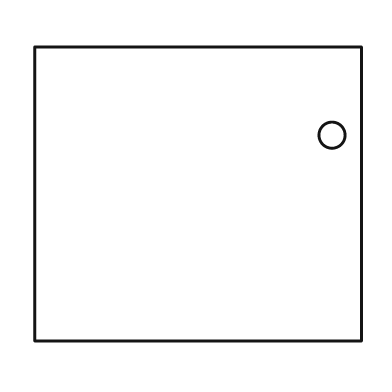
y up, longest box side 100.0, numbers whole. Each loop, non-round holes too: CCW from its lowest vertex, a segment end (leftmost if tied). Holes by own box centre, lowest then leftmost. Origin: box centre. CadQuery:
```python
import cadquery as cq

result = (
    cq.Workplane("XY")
    .moveTo(-50.0, -45.0)
    .lineTo(50.0, -45.0)
    .lineTo(50.0, 45.0)
    .lineTo(-50.0, 45.0)
    .close()
    .moveTo(41.0, 18.0)
    .circle(4.0)
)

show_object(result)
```